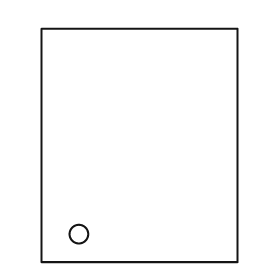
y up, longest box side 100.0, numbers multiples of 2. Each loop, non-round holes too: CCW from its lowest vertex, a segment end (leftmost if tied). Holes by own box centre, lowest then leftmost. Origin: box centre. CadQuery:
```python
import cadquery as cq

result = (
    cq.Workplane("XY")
    .moveTo(-42.0, -50.0)
    .lineTo(42.0, -50.0)
    .lineTo(42.0, 50.0)
    .lineTo(-42.0, 50.0)
    .close()
    .moveTo(-26.0, -38.0)
    .circle(4.0)
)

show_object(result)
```